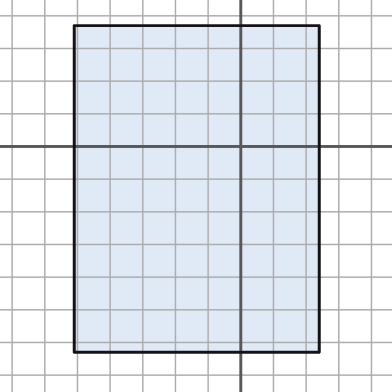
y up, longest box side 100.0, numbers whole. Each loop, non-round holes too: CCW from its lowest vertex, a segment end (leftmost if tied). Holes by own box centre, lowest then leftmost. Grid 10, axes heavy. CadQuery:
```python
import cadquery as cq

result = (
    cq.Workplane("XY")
    .moveTo(-51.0, -63.0)
    .lineTo(24.0, -63.0)
    .lineTo(24.0, 37.0)
    .lineTo(-51.0, 37.0)
    .close()
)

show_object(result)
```